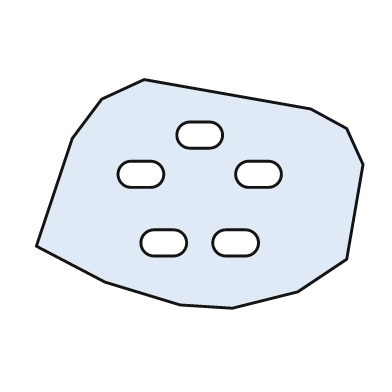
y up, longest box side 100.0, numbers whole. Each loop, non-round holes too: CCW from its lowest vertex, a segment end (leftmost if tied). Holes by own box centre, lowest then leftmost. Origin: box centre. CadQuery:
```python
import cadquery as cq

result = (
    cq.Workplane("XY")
    .moveTo(10.0, -35.0)
    .lineTo(30.0, -30.0)
    .lineTo(45.0, -20.0)
    .lineTo(50.0, 9.0)
    .lineTo(45.0, 20.0)
    .lineTo(34.0, 26.0)
    .lineTo(-17.0, 35.0)
    .lineTo(-30.0, 29.0)
    .lineTo(-39.0, 17.0)
    .lineTo(-50.0, -16.0)
    .lineTo(-29.0, -27.0)
    .lineTo(-6.0, -34.0)
    .close()
    .moveTo(-14.0, -19.0)
    .lineTo(-8.0, -19.0)
    .threePointArc((-4.0, -15.0), (-8.0, -11.0))
    .lineTo(-14.0, -11.0)
    .threePointArc((-18.0, -15.0), (-14.0, -19.0))
    .close()
    .moveTo(8.0, -19.0)
    .lineTo(14.0, -19.0)
    .threePointArc((18.0, -15.0), (14.0, -11.0))
    .lineTo(8.0, -11.0)
    .threePointArc((4.0, -15.0), (8.0, -19.0))
    .close()
    .moveTo(-21.0, 2.0)
    .lineTo(-15.0, 2.0)
    .threePointArc((-11.0, 6.0), (-15.0, 10.0))
    .lineTo(-21.0, 10.0)
    .threePointArc((-25.0, 6.0), (-21.0, 2.0))
    .close()
    .moveTo(15.0, 2.0)
    .lineTo(21.0, 2.0)
    .threePointArc((25.0, 6.0), (21.0, 10.0))
    .lineTo(15.0, 10.0)
    .threePointArc((11.0, 6.0), (15.0, 2.0))
    .close()
    .moveTo(-3.0, 14.0)
    .lineTo(3.0, 14.0)
    .threePointArc((7.0, 18.0), (3.0, 22.0))
    .lineTo(-3.0, 22.0)
    .threePointArc((-7.0, 18.0), (-3.0, 14.0))
    .close()
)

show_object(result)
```